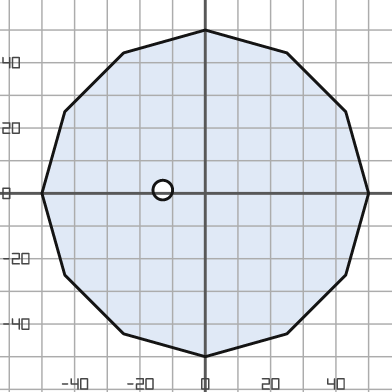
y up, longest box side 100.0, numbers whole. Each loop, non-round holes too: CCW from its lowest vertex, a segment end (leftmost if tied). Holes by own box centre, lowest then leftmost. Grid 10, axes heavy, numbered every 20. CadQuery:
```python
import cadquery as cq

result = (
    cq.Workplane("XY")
    .moveTo(0.0, -50.0)
    .lineTo(25.0, -43.0)
    .lineTo(43.0, -25.0)
    .lineTo(50.0, 0.0)
    .lineTo(43.0, 25.0)
    .lineTo(25.0, 43.0)
    .lineTo(0.0, 50.0)
    .lineTo(-25.0, 43.0)
    .lineTo(-43.0, 25.0)
    .lineTo(-50.0, 0.0)
    .lineTo(-43.0, -25.0)
    .lineTo(-25.0, -43.0)
    .close()
    .moveTo(-13.0, 1.0)
    .circle(3.0)
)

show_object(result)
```